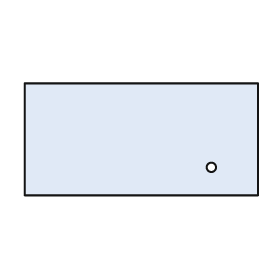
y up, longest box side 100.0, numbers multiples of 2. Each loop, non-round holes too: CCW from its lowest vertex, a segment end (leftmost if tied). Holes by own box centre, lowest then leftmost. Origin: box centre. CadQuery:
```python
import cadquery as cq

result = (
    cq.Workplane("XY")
    .moveTo(-50.0, -24.0)
    .lineTo(50.0, -24.0)
    .lineTo(50.0, 24.0)
    .lineTo(-50.0, 24.0)
    .close()
    .moveTo(30.0, -12.0)
    .circle(2.0)
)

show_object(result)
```